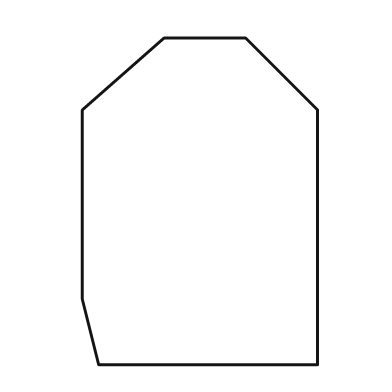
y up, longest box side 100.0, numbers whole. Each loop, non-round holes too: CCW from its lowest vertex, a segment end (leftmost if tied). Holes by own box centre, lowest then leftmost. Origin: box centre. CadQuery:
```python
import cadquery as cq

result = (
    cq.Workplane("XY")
    .moveTo(-31.0, -50.0)
    .lineTo(36.0, -50.0)
    .lineTo(36.0, 28.0)
    .lineTo(14.0, 50.0)
    .lineTo(-11.0, 50.0)
    .lineTo(-36.0, 28.0)
    .lineTo(-36.0, -30.0)
    .close()
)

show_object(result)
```